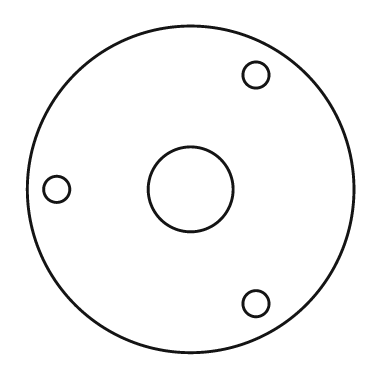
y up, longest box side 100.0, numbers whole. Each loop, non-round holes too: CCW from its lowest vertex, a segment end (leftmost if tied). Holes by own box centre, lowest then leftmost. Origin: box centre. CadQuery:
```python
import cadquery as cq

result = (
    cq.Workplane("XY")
    .moveTo(0.0, 0.0)
    .circle(50.0)
    .moveTo(20.0, -35.0)
    .circle(4.0)
    .moveTo(-41.0, 0.0)
    .circle(4.0)
    .moveTo(0.0, 0.0)
    .circle(13.0)
    .moveTo(20.0, 35.0)
    .circle(4.0)
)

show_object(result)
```